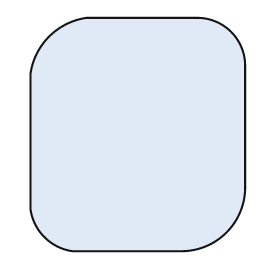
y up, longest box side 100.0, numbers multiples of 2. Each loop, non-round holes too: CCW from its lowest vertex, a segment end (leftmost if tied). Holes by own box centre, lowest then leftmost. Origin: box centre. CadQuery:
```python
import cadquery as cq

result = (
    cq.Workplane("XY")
    .moveTo(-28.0, -50.0)
    .lineTo(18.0, -50.0)
    .threePointArc((38.0, -42.0), (46.0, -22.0))
    .lineTo(46.0, 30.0)
    .threePointArc((40.0, 44.0), (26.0, 50.0))
    .lineTo(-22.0, 50.0)
    .threePointArc((-38.0, 42.0), (-46.0, 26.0))
    .lineTo(-46.0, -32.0)
    .threePointArc((-40.0, -44.0), (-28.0, -50.0))
    .close()
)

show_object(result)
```